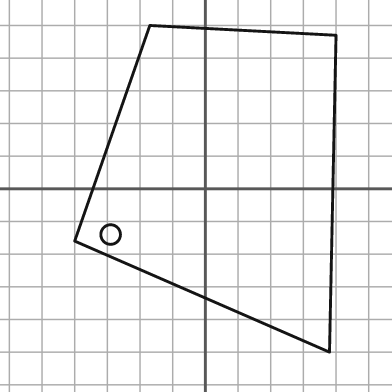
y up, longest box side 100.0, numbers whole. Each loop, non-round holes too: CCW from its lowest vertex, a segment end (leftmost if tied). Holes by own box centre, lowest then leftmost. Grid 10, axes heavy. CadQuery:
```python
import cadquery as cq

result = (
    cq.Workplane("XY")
    .moveTo(38.0, -50.0)
    .lineTo(40.0, 47.0)
    .lineTo(-17.0, 50.0)
    .lineTo(-40.0, -16.0)
    .close()
    .moveTo(-29.0, -14.0)
    .circle(3.0)
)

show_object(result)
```